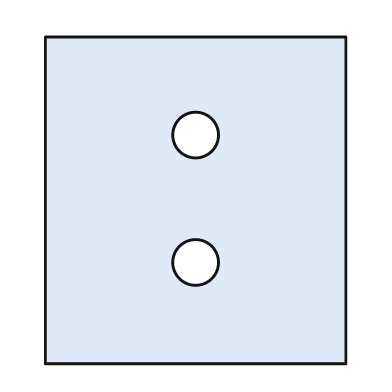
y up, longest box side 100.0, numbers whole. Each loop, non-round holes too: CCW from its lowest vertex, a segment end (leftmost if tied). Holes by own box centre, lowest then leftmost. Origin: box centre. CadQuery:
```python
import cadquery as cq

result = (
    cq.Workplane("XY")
    .moveTo(-46.0, -50.0)
    .lineTo(46.0, -50.0)
    .lineTo(46.0, 50.0)
    .lineTo(-46.0, 50.0)
    .close()
    .moveTo(0.0, -19.0)
    .circle(7.0)
    .moveTo(0.0, 20.0)
    .circle(7.0)
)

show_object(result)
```